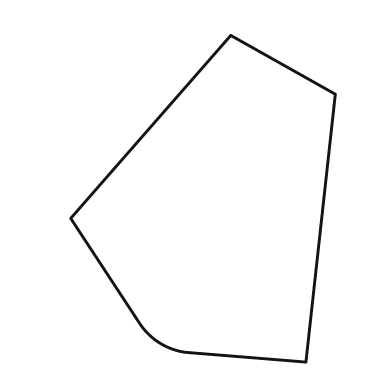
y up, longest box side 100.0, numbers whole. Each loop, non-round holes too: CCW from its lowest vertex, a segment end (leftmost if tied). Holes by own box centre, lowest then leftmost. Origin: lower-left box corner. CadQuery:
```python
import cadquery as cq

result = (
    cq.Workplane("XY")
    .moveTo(72.0, 0.0)
    .lineTo(81.0, 82.0)
    .lineTo(49.0, 100.0)
    .lineTo(0.0, 44.0)
    .lineTo(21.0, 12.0)
    .threePointArc((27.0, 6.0), (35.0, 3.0))
    .close()
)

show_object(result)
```